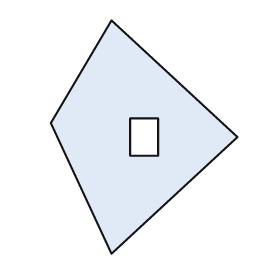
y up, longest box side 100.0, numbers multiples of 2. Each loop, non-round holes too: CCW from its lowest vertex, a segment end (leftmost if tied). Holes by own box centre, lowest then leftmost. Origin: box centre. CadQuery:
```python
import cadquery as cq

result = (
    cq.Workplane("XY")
    .moveTo(-14.0, -50.0)
    .lineTo(40.0, 0.0)
    .lineTo(-14.0, 50.0)
    .lineTo(-40.0, 6.0)
    .close()
    .moveTo(-6.0, -8.0)
    .lineTo(6.0, -8.0)
    .lineTo(6.0, 8.0)
    .lineTo(-6.0, 8.0)
    .close()
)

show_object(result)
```